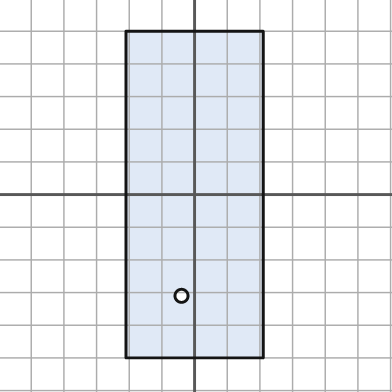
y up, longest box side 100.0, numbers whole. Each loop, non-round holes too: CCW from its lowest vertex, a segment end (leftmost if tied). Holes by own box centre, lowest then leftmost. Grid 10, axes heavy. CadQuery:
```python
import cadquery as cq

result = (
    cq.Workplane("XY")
    .moveTo(-21.0, -50.0)
    .lineTo(21.0, -50.0)
    .lineTo(21.0, 50.0)
    .lineTo(-21.0, 50.0)
    .close()
    .moveTo(-4.0, -31.0)
    .circle(2.0)
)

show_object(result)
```